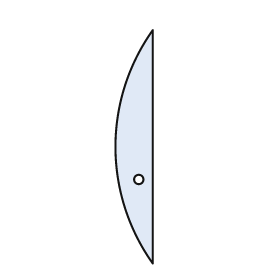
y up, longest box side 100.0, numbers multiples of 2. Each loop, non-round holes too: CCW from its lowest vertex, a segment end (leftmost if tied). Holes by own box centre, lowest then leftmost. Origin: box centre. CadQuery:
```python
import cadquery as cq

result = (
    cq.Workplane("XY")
    .moveTo(8.0, -50.0)
    .lineTo(8.0, 50.0)
    .threePointArc((-8.0, 0.0), (8.0, -50.0))
    .close()
    .moveTo(2.0, -14.0)
    .circle(2.0)
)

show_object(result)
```